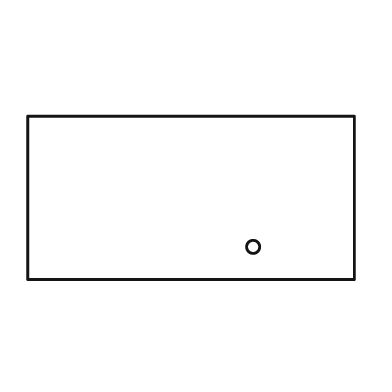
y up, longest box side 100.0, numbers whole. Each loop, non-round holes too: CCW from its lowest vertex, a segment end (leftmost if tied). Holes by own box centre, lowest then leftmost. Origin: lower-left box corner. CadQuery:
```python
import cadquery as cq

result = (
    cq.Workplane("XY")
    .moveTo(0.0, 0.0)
    .lineTo(100.0, 0.0)
    .lineTo(100.0, 50.0)
    .lineTo(0.0, 50.0)
    .close()
    .moveTo(69.0, 10.0)
    .circle(2.0)
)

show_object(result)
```